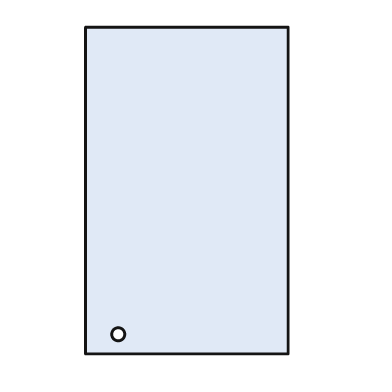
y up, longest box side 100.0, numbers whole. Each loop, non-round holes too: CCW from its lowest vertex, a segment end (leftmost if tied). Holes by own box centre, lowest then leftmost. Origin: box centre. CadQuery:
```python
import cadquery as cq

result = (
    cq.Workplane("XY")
    .moveTo(-31.0, -50.0)
    .lineTo(31.0, -50.0)
    .lineTo(31.0, 50.0)
    .lineTo(-31.0, 50.0)
    .close()
    .moveTo(-21.0, -44.0)
    .circle(2.0)
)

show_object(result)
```